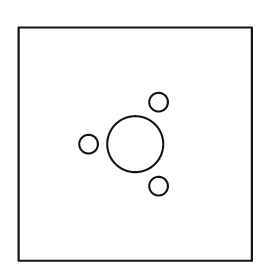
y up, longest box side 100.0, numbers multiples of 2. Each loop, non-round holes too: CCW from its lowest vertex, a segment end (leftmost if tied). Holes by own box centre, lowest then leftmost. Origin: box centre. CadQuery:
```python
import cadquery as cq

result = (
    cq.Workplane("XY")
    .moveTo(-50.0, -50.0)
    .lineTo(50.0, -50.0)
    .lineTo(50.0, 50.0)
    .lineTo(-50.0, 50.0)
    .close()
    .moveTo(10.0, -18.0)
    .circle(4.0)
    .moveTo(-20.0, 0.0)
    .circle(4.0)
    .moveTo(0.0, 0.0)
    .circle(12.0)
    .moveTo(10.0, 18.0)
    .circle(4.0)
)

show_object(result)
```